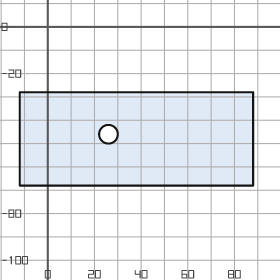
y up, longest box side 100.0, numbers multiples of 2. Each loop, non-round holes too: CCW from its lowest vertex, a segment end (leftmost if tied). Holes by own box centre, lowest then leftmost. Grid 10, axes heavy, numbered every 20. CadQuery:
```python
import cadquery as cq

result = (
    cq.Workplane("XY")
    .moveTo(-12.0, -68.0)
    .lineTo(88.0, -68.0)
    .lineTo(88.0, -28.0)
    .lineTo(-12.0, -28.0)
    .close()
    .moveTo(26.0, -46.0)
    .circle(4.0)
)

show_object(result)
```